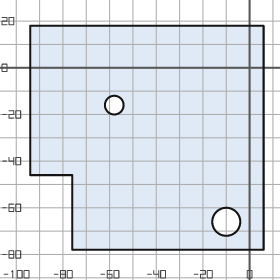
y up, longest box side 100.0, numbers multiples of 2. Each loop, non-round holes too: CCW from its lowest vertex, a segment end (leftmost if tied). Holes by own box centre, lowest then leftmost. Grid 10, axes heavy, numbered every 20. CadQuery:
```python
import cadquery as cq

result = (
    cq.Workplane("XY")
    .moveTo(-76.0, -78.0)
    .lineTo(6.0, -78.0)
    .lineTo(6.0, 18.0)
    .lineTo(-94.0, 18.0)
    .lineTo(-94.0, -46.0)
    .lineTo(-76.0, -46.0)
    .close()
    .moveTo(-10.0, -66.0)
    .circle(6.0)
    .moveTo(-58.0, -16.0)
    .circle(4.0)
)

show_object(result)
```